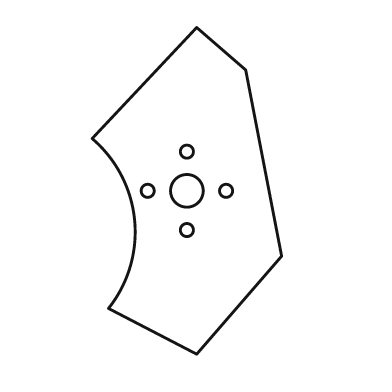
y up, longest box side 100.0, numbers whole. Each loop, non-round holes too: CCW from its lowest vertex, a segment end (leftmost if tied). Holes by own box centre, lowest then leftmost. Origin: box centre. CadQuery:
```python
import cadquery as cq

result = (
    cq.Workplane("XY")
    .moveTo(3.0, -50.0)
    .lineTo(29.0, -20.0)
    .lineTo(18.0, 37.0)
    .lineTo(3.0, 50.0)
    .lineTo(-29.0, 16.0)
    .threePointArc((-16.0, -9.0), (-24.0, -36.0))
    .close()
    .moveTo(0.0, -12.0)
    .circle(2.0)
    .moveTo(-12.0, 0.0)
    .circle(2.0)
    .moveTo(0.0, 0.0)
    .circle(5.0)
    .moveTo(12.0, 0.0)
    .circle(2.0)
    .moveTo(0.0, 12.0)
    .circle(2.0)
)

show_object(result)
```